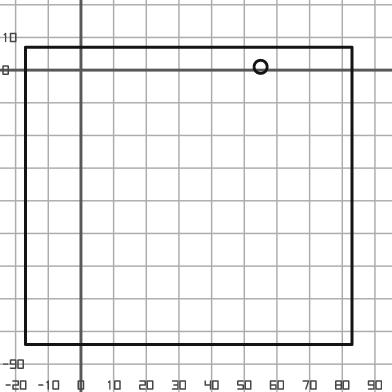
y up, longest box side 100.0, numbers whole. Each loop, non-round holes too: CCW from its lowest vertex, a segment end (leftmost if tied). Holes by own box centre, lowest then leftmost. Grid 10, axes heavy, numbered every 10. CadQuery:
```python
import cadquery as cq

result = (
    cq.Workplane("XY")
    .moveTo(-17.0, -84.0)
    .lineTo(83.0, -84.0)
    .lineTo(83.0, 7.0)
    .lineTo(-17.0, 7.0)
    .close()
    .moveTo(55.0, 1.0)
    .circle(2.0)
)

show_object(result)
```